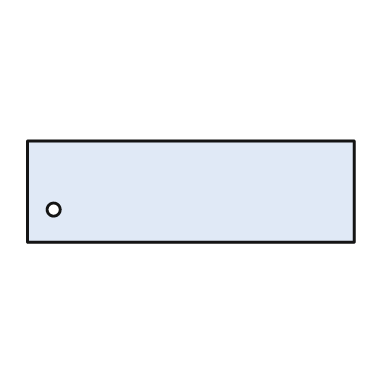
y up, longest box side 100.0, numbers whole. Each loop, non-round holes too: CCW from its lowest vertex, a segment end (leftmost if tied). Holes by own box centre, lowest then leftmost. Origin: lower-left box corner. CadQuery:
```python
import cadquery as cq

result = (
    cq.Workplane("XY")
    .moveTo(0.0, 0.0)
    .lineTo(100.0, 0.0)
    .lineTo(100.0, 31.0)
    .lineTo(0.0, 31.0)
    .close()
    .moveTo(8.0, 10.0)
    .circle(2.0)
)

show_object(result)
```